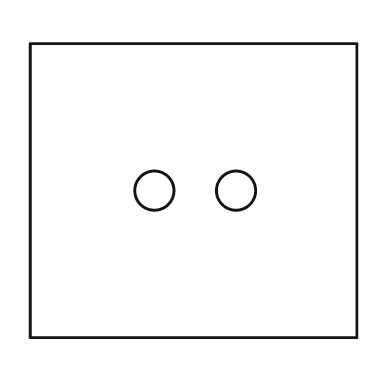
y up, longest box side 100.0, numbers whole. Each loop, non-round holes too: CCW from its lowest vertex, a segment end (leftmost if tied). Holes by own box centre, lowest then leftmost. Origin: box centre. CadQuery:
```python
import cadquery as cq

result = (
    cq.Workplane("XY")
    .moveTo(-50.0, -45.0)
    .lineTo(50.0, -45.0)
    .lineTo(50.0, 45.0)
    .lineTo(-50.0, 45.0)
    .close()
    .moveTo(-12.0, 0.0)
    .circle(6.0)
    .moveTo(13.0, 0.0)
    .circle(6.0)
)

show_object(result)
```